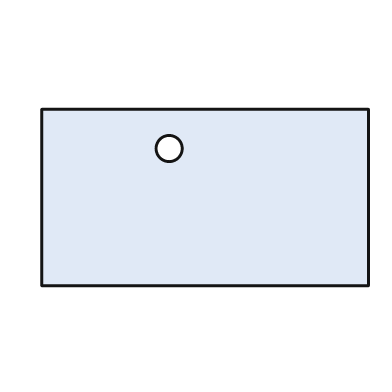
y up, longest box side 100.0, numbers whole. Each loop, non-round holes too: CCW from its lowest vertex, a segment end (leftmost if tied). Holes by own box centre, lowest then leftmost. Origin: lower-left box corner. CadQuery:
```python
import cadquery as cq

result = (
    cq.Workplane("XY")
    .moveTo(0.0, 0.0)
    .lineTo(100.0, 0.0)
    .lineTo(100.0, 54.0)
    .lineTo(0.0, 54.0)
    .close()
    .moveTo(39.0, 42.0)
    .circle(4.0)
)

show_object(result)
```